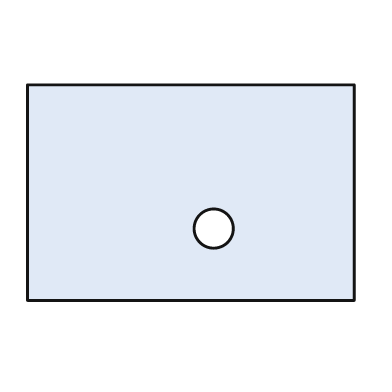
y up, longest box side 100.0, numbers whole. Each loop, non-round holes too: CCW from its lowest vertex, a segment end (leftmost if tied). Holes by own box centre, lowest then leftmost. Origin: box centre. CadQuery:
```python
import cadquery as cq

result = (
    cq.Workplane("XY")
    .moveTo(-50.0, -33.0)
    .lineTo(50.0, -33.0)
    .lineTo(50.0, 33.0)
    .lineTo(-50.0, 33.0)
    .close()
    .moveTo(7.0, -11.0)
    .circle(6.0)
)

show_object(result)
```